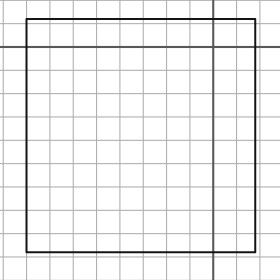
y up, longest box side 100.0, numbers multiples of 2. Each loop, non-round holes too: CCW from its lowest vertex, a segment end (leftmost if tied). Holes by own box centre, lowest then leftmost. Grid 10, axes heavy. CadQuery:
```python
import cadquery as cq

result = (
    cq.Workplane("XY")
    .moveTo(-80.0, -88.0)
    .lineTo(18.0, -88.0)
    .lineTo(18.0, 12.0)
    .lineTo(-80.0, 12.0)
    .close()
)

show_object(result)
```